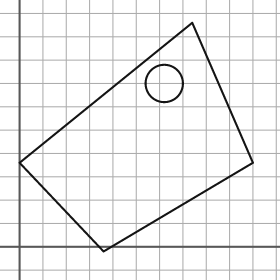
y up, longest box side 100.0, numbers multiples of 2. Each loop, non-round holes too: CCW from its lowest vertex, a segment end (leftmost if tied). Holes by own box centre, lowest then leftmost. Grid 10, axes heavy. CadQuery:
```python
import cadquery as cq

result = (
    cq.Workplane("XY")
    .moveTo(36.0, -2.0)
    .lineTo(100.0, 36.0)
    .lineTo(74.0, 96.0)
    .lineTo(0.0, 36.0)
    .close()
    .moveTo(62.0, 70.0)
    .circle(8.0)
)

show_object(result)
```